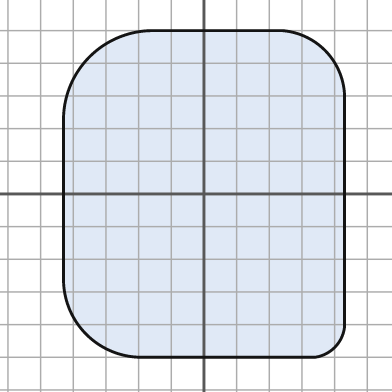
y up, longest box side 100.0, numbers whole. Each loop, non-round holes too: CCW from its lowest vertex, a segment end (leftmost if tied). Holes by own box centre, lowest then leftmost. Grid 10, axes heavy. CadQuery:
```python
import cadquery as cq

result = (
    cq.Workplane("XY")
    .moveTo(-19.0, -50.0)
    .lineTo(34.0, -50.0)
    .threePointArc((40.0, -47.0), (43.0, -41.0))
    .lineTo(43.0, 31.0)
    .threePointArc((37.0, 44.0), (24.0, 50.0))
    .lineTo(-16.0, 50.0)
    .threePointArc((-35.0, 42.0), (-43.0, 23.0))
    .lineTo(-43.0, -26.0)
    .threePointArc((-36.0, -43.0), (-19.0, -50.0))
    .close()
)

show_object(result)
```